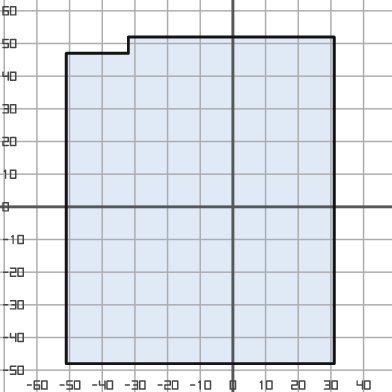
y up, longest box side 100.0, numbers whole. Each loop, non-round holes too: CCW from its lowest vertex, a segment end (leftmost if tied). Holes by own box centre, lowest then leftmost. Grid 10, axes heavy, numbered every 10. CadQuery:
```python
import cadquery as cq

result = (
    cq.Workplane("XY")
    .moveTo(-51.0, -48.0)
    .lineTo(31.0, -48.0)
    .lineTo(31.0, 52.0)
    .lineTo(-32.0, 52.0)
    .lineTo(-32.0, 47.0)
    .lineTo(-51.0, 47.0)
    .close()
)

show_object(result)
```